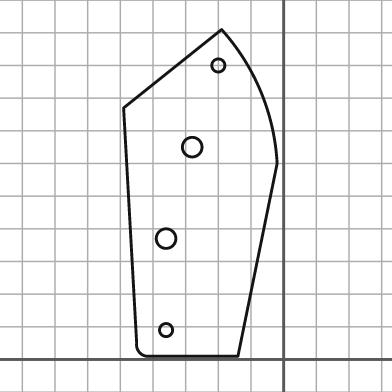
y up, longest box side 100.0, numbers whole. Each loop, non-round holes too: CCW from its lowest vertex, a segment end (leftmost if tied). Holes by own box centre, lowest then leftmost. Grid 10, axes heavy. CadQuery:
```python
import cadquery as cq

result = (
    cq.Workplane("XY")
    .moveTo(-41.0, 1.0)
    .lineTo(-14.0, 1.0)
    .lineTo(-2.0, 60.0)
    .threePointArc((-7.0, 82.0), (-19.0, 101.0))
    .lineTo(-49.0, 77.0)
    .lineTo(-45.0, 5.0)
    .threePointArc((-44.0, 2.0), (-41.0, 1.0))
    .close()
    .moveTo(-36.0, 9.0)
    .circle(2.0)
    .moveTo(-36.0, 37.0)
    .circle(3.0)
    .moveTo(-28.0, 65.0)
    .circle(3.0)
    .moveTo(-20.0, 90.0)
    .circle(2.0)
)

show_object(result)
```